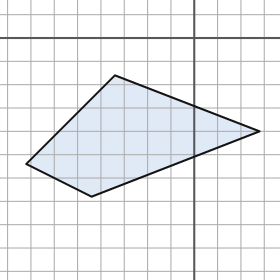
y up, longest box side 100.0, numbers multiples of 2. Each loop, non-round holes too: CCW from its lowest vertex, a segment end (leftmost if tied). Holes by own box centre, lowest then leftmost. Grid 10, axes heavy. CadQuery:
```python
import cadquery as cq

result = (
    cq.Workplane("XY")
    .moveTo(-44.0, -68.0)
    .lineTo(28.0, -40.0)
    .lineTo(-34.0, -16.0)
    .lineTo(-72.0, -54.0)
    .close()
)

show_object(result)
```